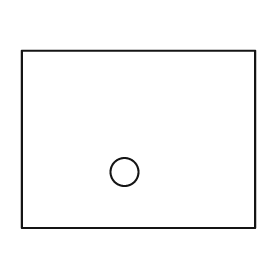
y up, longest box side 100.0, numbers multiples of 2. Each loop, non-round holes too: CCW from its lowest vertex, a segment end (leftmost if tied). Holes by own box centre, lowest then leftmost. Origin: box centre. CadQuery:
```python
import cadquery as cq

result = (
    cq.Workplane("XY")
    .moveTo(-50.0, -38.0)
    .lineTo(50.0, -38.0)
    .lineTo(50.0, 38.0)
    .lineTo(-50.0, 38.0)
    .close()
    .moveTo(-6.0, -14.0)
    .circle(6.0)
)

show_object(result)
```